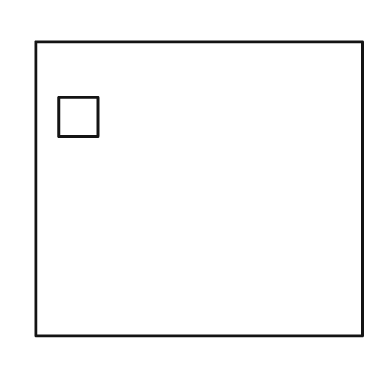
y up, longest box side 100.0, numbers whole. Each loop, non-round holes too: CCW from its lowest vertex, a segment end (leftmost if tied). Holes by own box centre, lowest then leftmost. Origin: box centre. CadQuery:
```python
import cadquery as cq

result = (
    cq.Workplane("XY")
    .moveTo(-50.0, -45.0)
    .lineTo(50.0, -45.0)
    .lineTo(50.0, 45.0)
    .lineTo(-50.0, 45.0)
    .close()
    .moveTo(-43.0, 16.0)
    .lineTo(-31.0, 16.0)
    .lineTo(-31.0, 28.0)
    .lineTo(-43.0, 28.0)
    .close()
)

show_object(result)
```